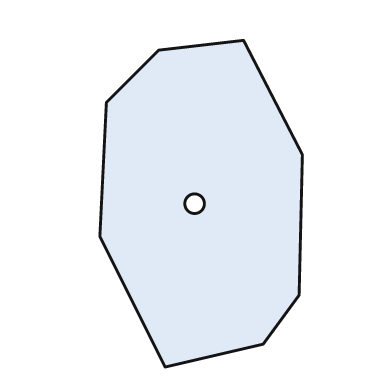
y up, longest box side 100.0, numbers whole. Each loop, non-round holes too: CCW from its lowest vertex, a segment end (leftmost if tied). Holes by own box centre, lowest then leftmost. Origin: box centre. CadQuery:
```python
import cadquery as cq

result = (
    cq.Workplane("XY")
    .moveTo(-11.0, -50.0)
    .lineTo(19.0, -43.0)
    .lineTo(30.0, -28.0)
    .lineTo(31.0, 15.0)
    .lineTo(13.0, 50.0)
    .lineTo(-13.0, 47.0)
    .lineTo(-29.0, 31.0)
    .lineTo(-31.0, -10.0)
    .close()
    .moveTo(-2.0, 0.0)
    .circle(3.0)
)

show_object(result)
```